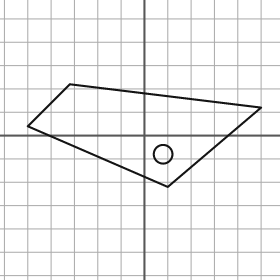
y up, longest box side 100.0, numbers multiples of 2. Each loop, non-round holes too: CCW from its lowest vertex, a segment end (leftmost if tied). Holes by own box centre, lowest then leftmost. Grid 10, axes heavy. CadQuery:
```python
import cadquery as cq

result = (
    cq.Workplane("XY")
    .moveTo(10.0, -22.0)
    .lineTo(50.0, 12.0)
    .lineTo(-32.0, 22.0)
    .lineTo(-50.0, 4.0)
    .close()
    .moveTo(8.0, -8.0)
    .circle(4.0)
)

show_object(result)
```